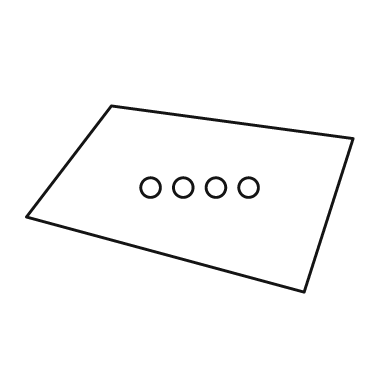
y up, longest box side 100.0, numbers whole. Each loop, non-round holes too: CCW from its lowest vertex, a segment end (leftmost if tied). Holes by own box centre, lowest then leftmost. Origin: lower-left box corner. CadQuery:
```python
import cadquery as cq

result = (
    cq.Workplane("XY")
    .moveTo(85.0, 0.0)
    .lineTo(100.0, 47.0)
    .lineTo(26.0, 57.0)
    .lineTo(0.0, 23.0)
    .close()
    .moveTo(38.0, 32.0)
    .circle(3.0)
    .moveTo(48.0, 32.0)
    .circle(3.0)
    .moveTo(58.0, 32.0)
    .circle(3.0)
    .moveTo(68.0, 32.0)
    .circle(3.0)
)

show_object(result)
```